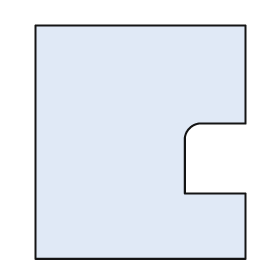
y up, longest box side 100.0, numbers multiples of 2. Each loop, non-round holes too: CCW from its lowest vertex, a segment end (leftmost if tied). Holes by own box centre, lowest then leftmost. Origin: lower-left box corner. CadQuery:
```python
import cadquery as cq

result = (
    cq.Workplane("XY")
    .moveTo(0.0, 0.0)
    .lineTo(90.0, 0.0)
    .lineTo(90.0, 28.0)
    .lineTo(64.0, 28.0)
    .lineTo(64.0, 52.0)
    .threePointArc((66.0, 56.0), (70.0, 58.0))
    .lineTo(90.0, 58.0)
    .lineTo(90.0, 100.0)
    .lineTo(0.0, 100.0)
    .close()
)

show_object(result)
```